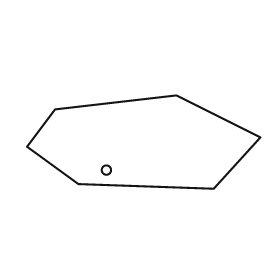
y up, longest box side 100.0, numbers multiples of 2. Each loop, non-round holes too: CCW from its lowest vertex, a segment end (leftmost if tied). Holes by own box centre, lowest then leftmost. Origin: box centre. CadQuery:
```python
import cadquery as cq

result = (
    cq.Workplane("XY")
    .moveTo(30.0, -20.0)
    .lineTo(50.0, 2.0)
    .lineTo(14.0, 20.0)
    .lineTo(-38.0, 14.0)
    .lineTo(-50.0, -2.0)
    .lineTo(-28.0, -18.0)
    .close()
    .moveTo(-16.0, -12.0)
    .circle(2.0)
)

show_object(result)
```